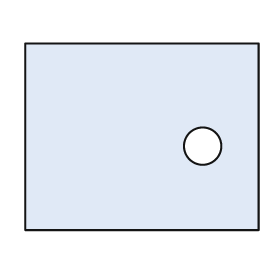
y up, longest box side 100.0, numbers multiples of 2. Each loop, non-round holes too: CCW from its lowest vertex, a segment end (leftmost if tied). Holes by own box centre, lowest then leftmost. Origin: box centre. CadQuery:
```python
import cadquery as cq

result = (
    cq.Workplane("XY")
    .moveTo(-50.0, -40.0)
    .lineTo(50.0, -40.0)
    .lineTo(50.0, 40.0)
    .lineTo(-50.0, 40.0)
    .close()
    .moveTo(26.0, -4.0)
    .circle(8.0)
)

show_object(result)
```